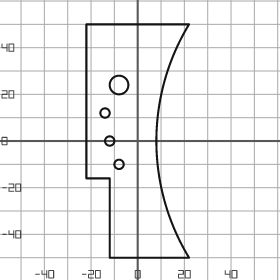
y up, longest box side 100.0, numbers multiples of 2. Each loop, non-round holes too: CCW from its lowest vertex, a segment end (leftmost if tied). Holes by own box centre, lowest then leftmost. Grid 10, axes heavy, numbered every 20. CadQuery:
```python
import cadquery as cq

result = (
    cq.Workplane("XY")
    .moveTo(-12.0, -50.0)
    .lineTo(22.0, -50.0)
    .threePointArc((8.0, 0.0), (22.0, 50.0))
    .lineTo(-22.0, 50.0)
    .lineTo(-22.0, -16.0)
    .lineTo(-12.0, -16.0)
    .close()
    .moveTo(-8.0, -10.0)
    .circle(2.0)
    .moveTo(-12.0, 0.0)
    .circle(2.0)
    .moveTo(-14.0, 12.0)
    .circle(2.0)
    .moveTo(-8.0, 24.0)
    .circle(4.0)
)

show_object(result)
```